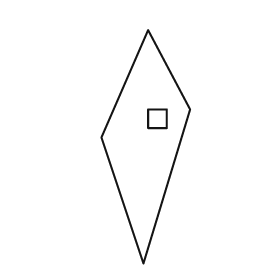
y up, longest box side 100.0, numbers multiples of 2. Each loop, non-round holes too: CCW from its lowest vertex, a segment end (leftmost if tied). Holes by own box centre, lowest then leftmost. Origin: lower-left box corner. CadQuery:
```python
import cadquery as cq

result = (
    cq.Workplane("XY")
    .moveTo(18.0, 0.0)
    .lineTo(38.0, 66.0)
    .lineTo(20.0, 100.0)
    .lineTo(0.0, 54.0)
    .close()
    .moveTo(20.0, 58.0)
    .lineTo(28.0, 58.0)
    .lineTo(28.0, 66.0)
    .lineTo(20.0, 66.0)
    .close()
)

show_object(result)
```